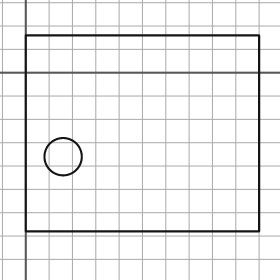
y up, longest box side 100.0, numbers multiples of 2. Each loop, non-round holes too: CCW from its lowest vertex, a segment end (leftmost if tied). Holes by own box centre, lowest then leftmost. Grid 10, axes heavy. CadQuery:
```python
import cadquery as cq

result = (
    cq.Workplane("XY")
    .moveTo(0.0, -68.0)
    .lineTo(100.0, -68.0)
    .lineTo(100.0, 16.0)
    .lineTo(0.0, 16.0)
    .close()
    .moveTo(16.0, -36.0)
    .circle(8.0)
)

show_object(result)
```